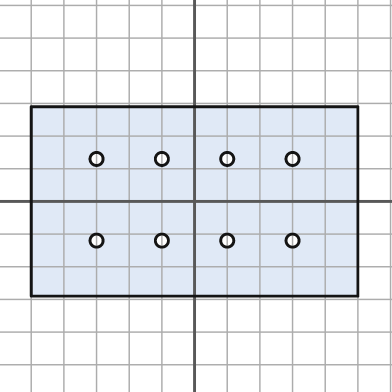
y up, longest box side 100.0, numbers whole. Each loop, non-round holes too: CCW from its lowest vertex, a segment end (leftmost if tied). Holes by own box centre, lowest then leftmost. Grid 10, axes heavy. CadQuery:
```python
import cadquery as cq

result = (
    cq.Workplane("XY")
    .moveTo(-50.0, -29.0)
    .lineTo(50.0, -29.0)
    .lineTo(50.0, 29.0)
    .lineTo(-50.0, 29.0)
    .close()
    .moveTo(-30.0, -12.0)
    .circle(2.0)
    .moveTo(-10.0, -12.0)
    .circle(2.0)
    .moveTo(10.0, -12.0)
    .circle(2.0)
    .moveTo(30.0, -12.0)
    .circle(2.0)
    .moveTo(-30.0, 13.0)
    .circle(2.0)
    .moveTo(-10.0, 13.0)
    .circle(2.0)
    .moveTo(10.0, 13.0)
    .circle(2.0)
    .moveTo(30.0, 13.0)
    .circle(2.0)
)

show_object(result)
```